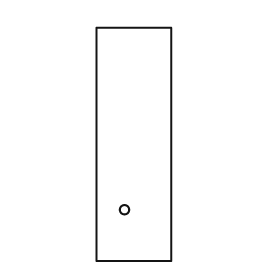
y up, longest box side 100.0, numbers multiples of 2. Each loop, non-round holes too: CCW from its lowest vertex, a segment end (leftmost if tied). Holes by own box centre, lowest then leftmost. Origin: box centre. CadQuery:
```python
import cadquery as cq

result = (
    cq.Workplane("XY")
    .moveTo(-16.0, -50.0)
    .lineTo(16.0, -50.0)
    .lineTo(16.0, 50.0)
    .lineTo(-16.0, 50.0)
    .close()
    .moveTo(-4.0, -28.0)
    .circle(2.0)
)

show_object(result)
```